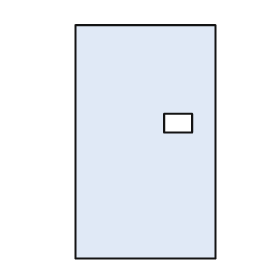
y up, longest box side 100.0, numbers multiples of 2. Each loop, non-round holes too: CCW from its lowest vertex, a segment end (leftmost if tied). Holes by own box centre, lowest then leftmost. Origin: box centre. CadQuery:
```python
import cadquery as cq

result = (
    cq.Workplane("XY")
    .moveTo(-30.0, -50.0)
    .lineTo(30.0, -50.0)
    .lineTo(30.0, 50.0)
    .lineTo(-30.0, 50.0)
    .close()
    .moveTo(8.0, 4.0)
    .lineTo(20.0, 4.0)
    .lineTo(20.0, 12.0)
    .lineTo(8.0, 12.0)
    .close()
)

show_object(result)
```